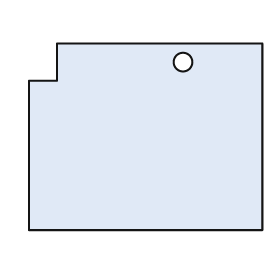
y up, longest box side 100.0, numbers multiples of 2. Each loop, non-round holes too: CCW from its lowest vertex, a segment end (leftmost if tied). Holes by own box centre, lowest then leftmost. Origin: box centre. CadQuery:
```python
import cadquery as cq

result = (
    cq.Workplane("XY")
    .moveTo(-50.0, -40.0)
    .lineTo(50.0, -40.0)
    .lineTo(50.0, 40.0)
    .lineTo(-38.0, 40.0)
    .lineTo(-38.0, 24.0)
    .lineTo(-50.0, 24.0)
    .close()
    .moveTo(16.0, 32.0)
    .circle(4.0)
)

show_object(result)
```